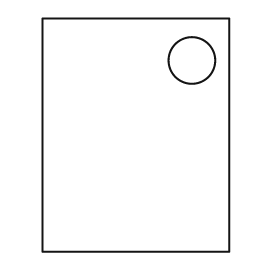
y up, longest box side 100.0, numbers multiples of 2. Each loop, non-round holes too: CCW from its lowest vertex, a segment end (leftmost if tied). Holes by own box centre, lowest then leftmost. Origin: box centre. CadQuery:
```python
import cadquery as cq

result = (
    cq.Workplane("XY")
    .moveTo(-40.0, -50.0)
    .lineTo(40.0, -50.0)
    .lineTo(40.0, 50.0)
    .lineTo(-40.0, 50.0)
    .close()
    .moveTo(24.0, 32.0)
    .circle(10.0)
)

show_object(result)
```